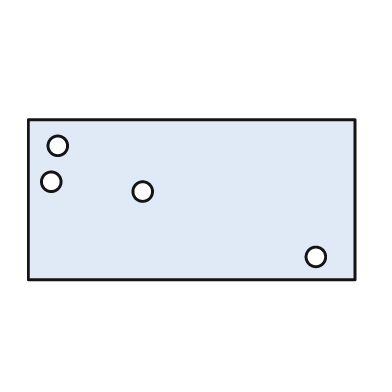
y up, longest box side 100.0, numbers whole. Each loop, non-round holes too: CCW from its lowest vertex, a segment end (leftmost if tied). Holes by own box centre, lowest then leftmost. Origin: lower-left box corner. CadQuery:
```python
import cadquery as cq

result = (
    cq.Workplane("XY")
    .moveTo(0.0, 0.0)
    .lineTo(100.0, 0.0)
    .lineTo(100.0, 49.0)
    .lineTo(0.0, 49.0)
    .close()
    .moveTo(88.0, 7.0)
    .circle(3.0)
    .moveTo(35.0, 27.0)
    .circle(3.0)
    .moveTo(7.0, 30.0)
    .circle(3.0)
    .moveTo(9.0, 41.0)
    .circle(3.0)
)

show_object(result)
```